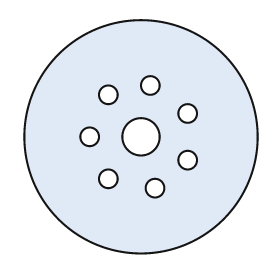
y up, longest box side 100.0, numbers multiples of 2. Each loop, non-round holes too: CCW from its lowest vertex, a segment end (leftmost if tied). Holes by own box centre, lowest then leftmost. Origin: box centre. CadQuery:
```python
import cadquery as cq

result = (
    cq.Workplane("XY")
    .moveTo(0.0, 0.0)
    .circle(50.0)
    .moveTo(6.0, -22.0)
    .circle(4.0)
    .moveTo(-14.0, -18.0)
    .circle(4.0)
    .moveTo(20.0, -10.0)
    .circle(4.0)
    .moveTo(-22.0, 0.0)
    .circle(4.0)
    .moveTo(0.0, 0.0)
    .circle(8.0)
    .moveTo(20.0, 10.0)
    .circle(4.0)
    .moveTo(-14.0, 18.0)
    .circle(4.0)
    .moveTo(4.0, 22.0)
    .circle(4.0)
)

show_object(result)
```